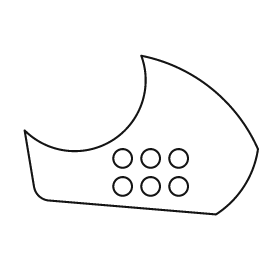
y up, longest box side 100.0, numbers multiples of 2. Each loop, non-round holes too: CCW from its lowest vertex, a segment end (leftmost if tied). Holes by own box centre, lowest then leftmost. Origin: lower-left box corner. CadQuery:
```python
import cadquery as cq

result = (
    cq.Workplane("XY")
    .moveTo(82.0, 0.0)
    .threePointArc((94.0, 12.0), (100.0, 28.0))
    .threePointArc((80.0, 54.0), (50.0, 68.0))
    .threePointArc((38.0, 32.0), (0.0, 36.0))
    .lineTo(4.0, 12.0)
    .threePointArc((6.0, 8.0), (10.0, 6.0))
    .close()
    .moveTo(42.0, 12.0)
    .circle(4.0)
    .moveTo(54.0, 12.0)
    .circle(4.0)
    .moveTo(66.0, 12.0)
    .circle(4.0)
    .moveTo(42.0, 24.0)
    .circle(4.0)
    .moveTo(54.0, 24.0)
    .circle(4.0)
    .moveTo(66.0, 24.0)
    .circle(4.0)
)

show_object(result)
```